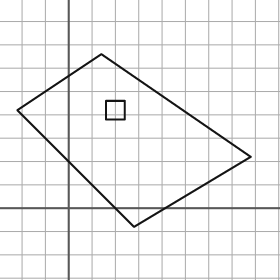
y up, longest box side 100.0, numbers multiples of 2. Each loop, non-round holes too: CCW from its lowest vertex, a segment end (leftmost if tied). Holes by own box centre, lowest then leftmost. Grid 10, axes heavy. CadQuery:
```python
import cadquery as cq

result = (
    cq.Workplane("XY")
    .moveTo(28.0, -8.0)
    .lineTo(78.0, 22.0)
    .lineTo(14.0, 66.0)
    .lineTo(-22.0, 42.0)
    .close()
    .moveTo(16.0, 38.0)
    .lineTo(24.0, 38.0)
    .lineTo(24.0, 46.0)
    .lineTo(16.0, 46.0)
    .close()
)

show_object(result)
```